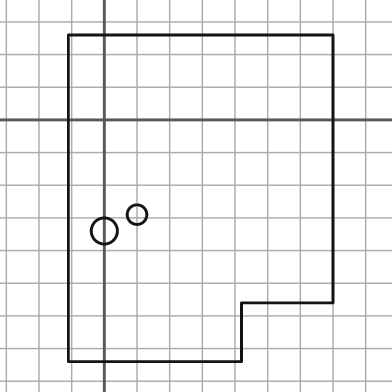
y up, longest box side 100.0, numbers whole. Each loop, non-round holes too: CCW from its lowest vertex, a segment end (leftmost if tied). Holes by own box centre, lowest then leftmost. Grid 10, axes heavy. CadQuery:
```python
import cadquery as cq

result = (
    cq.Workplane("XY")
    .moveTo(-11.0, -74.0)
    .lineTo(42.0, -74.0)
    .lineTo(42.0, -56.0)
    .lineTo(70.0, -56.0)
    .lineTo(70.0, 26.0)
    .lineTo(-11.0, 26.0)
    .close()
    .moveTo(0.0, -34.0)
    .circle(4.0)
    .moveTo(10.0, -29.0)
    .circle(3.0)
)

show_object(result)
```